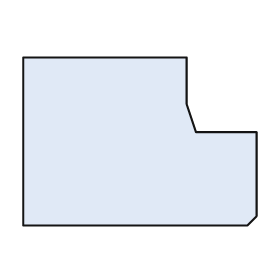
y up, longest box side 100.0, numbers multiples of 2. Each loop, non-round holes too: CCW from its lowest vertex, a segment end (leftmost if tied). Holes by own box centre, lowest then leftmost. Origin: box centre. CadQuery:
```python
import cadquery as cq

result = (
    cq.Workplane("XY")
    .moveTo(-50.0, -36.0)
    .lineTo(46.0, -36.0)
    .lineTo(50.0, -32.0)
    .lineTo(50.0, 4.0)
    .lineTo(24.0, 4.0)
    .lineTo(20.0, 16.0)
    .lineTo(20.0, 36.0)
    .lineTo(-50.0, 36.0)
    .close()
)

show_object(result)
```